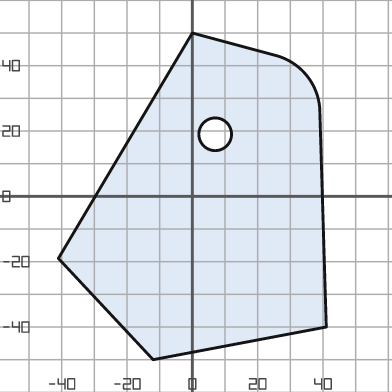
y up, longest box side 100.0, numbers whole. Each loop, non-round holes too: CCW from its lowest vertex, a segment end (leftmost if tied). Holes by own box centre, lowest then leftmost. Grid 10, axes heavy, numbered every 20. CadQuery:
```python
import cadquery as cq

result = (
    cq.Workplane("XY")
    .moveTo(-12.0, -50.0)
    .lineTo(41.0, -40.0)
    .lineTo(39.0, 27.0)
    .threePointArc((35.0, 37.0), (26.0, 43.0))
    .lineTo(0.0, 50.0)
    .lineTo(-41.0, -19.0)
    .close()
    .moveTo(7.0, 19.0)
    .circle(5.0)
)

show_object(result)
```